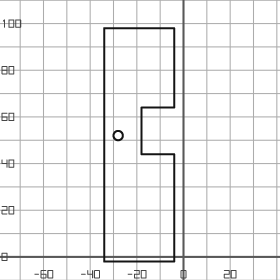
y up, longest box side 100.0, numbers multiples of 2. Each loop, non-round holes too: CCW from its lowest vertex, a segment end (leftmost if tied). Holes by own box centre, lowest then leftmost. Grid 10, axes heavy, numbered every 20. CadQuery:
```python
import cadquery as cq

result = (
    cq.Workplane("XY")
    .moveTo(-34.0, -2.0)
    .lineTo(-4.0, -2.0)
    .lineTo(-4.0, 44.0)
    .lineTo(-18.0, 44.0)
    .lineTo(-18.0, 64.0)
    .lineTo(-4.0, 64.0)
    .lineTo(-4.0, 98.0)
    .lineTo(-34.0, 98.0)
    .close()
    .moveTo(-28.0, 52.0)
    .circle(2.0)
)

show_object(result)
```